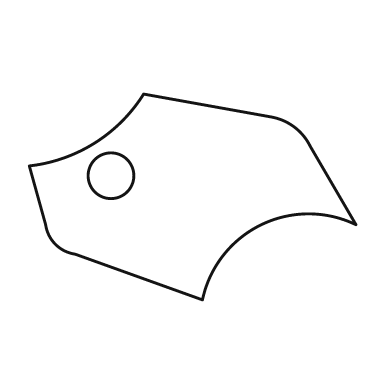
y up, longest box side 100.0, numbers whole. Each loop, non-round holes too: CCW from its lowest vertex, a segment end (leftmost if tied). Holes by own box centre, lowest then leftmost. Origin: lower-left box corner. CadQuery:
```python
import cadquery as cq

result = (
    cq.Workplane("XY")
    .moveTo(53.0, 0.0)
    .threePointArc((71.0, 23.0), (100.0, 23.0))
    .lineTo(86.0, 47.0)
    .threePointArc((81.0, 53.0), (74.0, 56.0))
    .lineTo(35.0, 63.0)
    .threePointArc((20.0, 48.0), (0.0, 41.0))
    .lineTo(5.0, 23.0)
    .threePointArc((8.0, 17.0), (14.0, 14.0))
    .close()
    .moveTo(25.0, 38.0)
    .circle(7.0)
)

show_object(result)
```